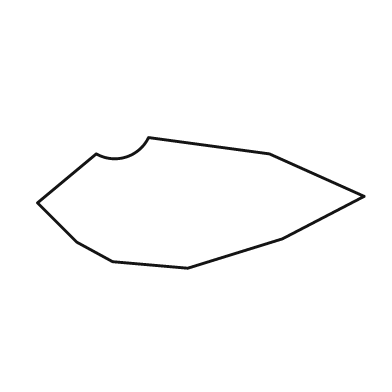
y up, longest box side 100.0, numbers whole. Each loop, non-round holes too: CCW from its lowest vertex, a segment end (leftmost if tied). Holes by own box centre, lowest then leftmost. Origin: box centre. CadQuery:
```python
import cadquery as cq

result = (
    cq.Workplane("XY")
    .moveTo(-4.0, -20.0)
    .lineTo(25.0, -11.0)
    .lineTo(50.0, 2.0)
    .lineTo(21.0, 15.0)
    .lineTo(-16.0, 20.0)
    .threePointArc((-23.0, 14.0), (-32.0, 15.0))
    .lineTo(-50.0, 0.0)
    .lineTo(-38.0, -12.0)
    .lineTo(-27.0, -18.0)
    .close()
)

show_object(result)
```